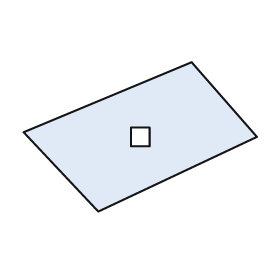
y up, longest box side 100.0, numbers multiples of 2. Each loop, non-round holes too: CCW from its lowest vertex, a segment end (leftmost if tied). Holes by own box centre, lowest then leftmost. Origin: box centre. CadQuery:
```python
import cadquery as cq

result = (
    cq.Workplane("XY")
    .moveTo(-18.0, -32.0)
    .lineTo(50.0, 0.0)
    .lineTo(22.0, 32.0)
    .lineTo(-50.0, 2.0)
    .close()
    .moveTo(-4.0, -4.0)
    .lineTo(4.0, -4.0)
    .lineTo(4.0, 4.0)
    .lineTo(-4.0, 4.0)
    .close()
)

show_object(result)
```